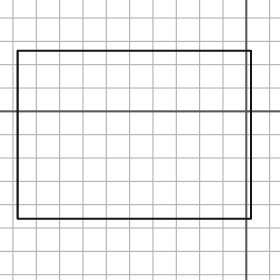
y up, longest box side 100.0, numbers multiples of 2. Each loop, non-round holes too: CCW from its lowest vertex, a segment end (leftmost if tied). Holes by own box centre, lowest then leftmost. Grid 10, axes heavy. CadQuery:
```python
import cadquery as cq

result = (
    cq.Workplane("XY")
    .moveTo(-98.0, -46.0)
    .lineTo(2.0, -46.0)
    .lineTo(2.0, 26.0)
    .lineTo(-98.0, 26.0)
    .close()
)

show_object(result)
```